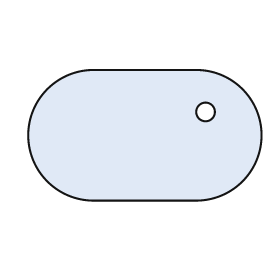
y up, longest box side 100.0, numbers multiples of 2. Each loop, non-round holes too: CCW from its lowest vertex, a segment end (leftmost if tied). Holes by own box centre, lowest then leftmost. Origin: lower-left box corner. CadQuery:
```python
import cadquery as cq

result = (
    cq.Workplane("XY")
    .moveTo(28.0, 0.0)
    .lineTo(72.0, 0.0)
    .threePointArc((100.0, 28.0), (72.0, 56.0))
    .lineTo(28.0, 56.0)
    .threePointArc((0.0, 28.0), (28.0, 0.0))
    .close()
    .moveTo(76.0, 38.0)
    .circle(4.0)
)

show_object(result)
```